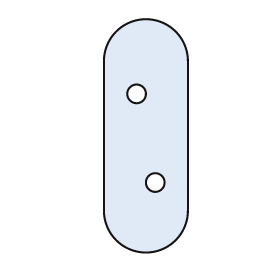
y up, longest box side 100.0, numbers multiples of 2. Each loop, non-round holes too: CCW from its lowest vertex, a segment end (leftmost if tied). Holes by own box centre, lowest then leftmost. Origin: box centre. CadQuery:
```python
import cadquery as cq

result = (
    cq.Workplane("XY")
    .moveTo(-18.0, -32.0)
    .threePointArc((0.0, -50.0), (18.0, -32.0))
    .lineTo(18.0, 32.0)
    .threePointArc((0.0, 50.0), (-18.0, 32.0))
    .close()
    .moveTo(4.0, -20.0)
    .circle(4.0)
    .moveTo(-4.0, 18.0)
    .circle(4.0)
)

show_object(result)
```